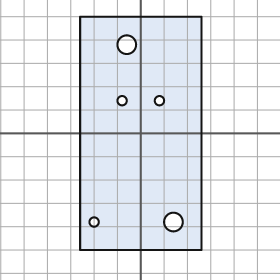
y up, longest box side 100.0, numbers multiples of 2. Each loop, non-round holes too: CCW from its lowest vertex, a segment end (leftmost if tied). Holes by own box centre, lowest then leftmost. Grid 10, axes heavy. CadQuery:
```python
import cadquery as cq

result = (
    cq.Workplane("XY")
    .moveTo(-26.0, -50.0)
    .lineTo(26.0, -50.0)
    .lineTo(26.0, 50.0)
    .lineTo(-26.0, 50.0)
    .close()
    .moveTo(-20.0, -38.0)
    .circle(2.0)
    .moveTo(14.0, -38.0)
    .circle(4.0)
    .moveTo(-8.0, 14.0)
    .circle(2.0)
    .moveTo(8.0, 14.0)
    .circle(2.0)
    .moveTo(-6.0, 38.0)
    .circle(4.0)
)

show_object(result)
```